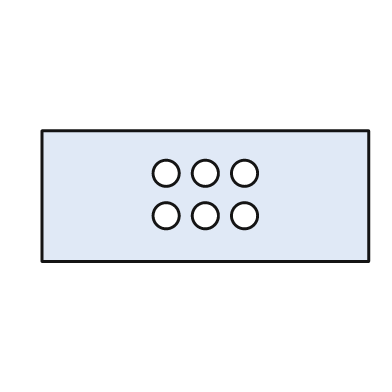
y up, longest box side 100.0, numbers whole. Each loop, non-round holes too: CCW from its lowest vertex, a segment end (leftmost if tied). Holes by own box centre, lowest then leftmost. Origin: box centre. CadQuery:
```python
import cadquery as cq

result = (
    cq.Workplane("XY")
    .moveTo(-50.0, -20.0)
    .lineTo(50.0, -20.0)
    .lineTo(50.0, 20.0)
    .lineTo(-50.0, 20.0)
    .close()
    .moveTo(-12.0, -6.0)
    .circle(4.0)
    .moveTo(0.0, -6.0)
    .circle(4.0)
    .moveTo(12.0, -6.0)
    .circle(4.0)
    .moveTo(-12.0, 7.0)
    .circle(4.0)
    .moveTo(0.0, 7.0)
    .circle(4.0)
    .moveTo(12.0, 7.0)
    .circle(4.0)
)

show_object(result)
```